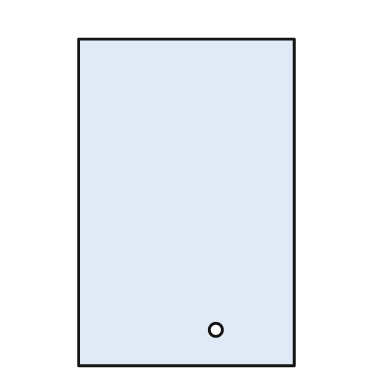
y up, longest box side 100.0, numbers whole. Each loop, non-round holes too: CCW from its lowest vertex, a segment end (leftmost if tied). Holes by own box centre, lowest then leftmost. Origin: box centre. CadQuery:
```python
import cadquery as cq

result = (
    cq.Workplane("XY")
    .moveTo(-33.0, -50.0)
    .lineTo(33.0, -50.0)
    .lineTo(33.0, 50.0)
    .lineTo(-33.0, 50.0)
    .close()
    .moveTo(9.0, -39.0)
    .circle(2.0)
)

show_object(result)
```